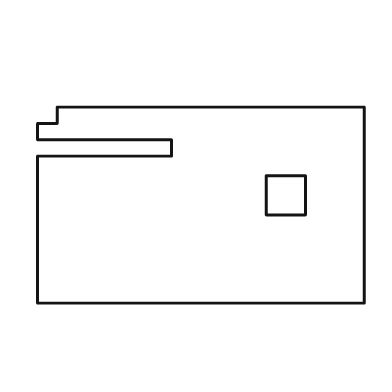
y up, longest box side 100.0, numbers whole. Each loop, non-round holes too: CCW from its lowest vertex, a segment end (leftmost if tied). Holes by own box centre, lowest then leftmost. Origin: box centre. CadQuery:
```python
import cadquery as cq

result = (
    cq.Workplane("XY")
    .moveTo(-50.0, -30.0)
    .lineTo(50.0, -30.0)
    .lineTo(50.0, 30.0)
    .lineTo(-44.0, 30.0)
    .lineTo(-44.0, 25.0)
    .lineTo(-50.0, 25.0)
    .lineTo(-50.0, 20.0)
    .lineTo(-9.0, 20.0)
    .lineTo(-9.0, 15.0)
    .lineTo(-50.0, 15.0)
    .close()
    .moveTo(20.0, -3.0)
    .lineTo(32.0, -3.0)
    .lineTo(32.0, 9.0)
    .lineTo(20.0, 9.0)
    .close()
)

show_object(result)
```